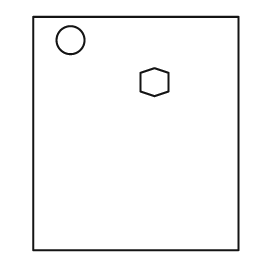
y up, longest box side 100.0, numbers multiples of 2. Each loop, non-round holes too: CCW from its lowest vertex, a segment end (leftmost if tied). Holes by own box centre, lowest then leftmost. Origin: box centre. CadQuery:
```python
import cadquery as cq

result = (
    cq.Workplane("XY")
    .moveTo(-44.0, -50.0)
    .lineTo(44.0, -50.0)
    .lineTo(44.0, 50.0)
    .lineTo(-44.0, 50.0)
    .close()
    .moveTo(8.0, 16.0)
    .lineTo(14.0, 18.0)
    .lineTo(14.0, 26.0)
    .lineTo(8.0, 28.0)
    .lineTo(2.0, 26.0)
    .lineTo(2.0, 18.0)
    .close()
    .moveTo(-28.0, 40.0)
    .circle(6.0)
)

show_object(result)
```